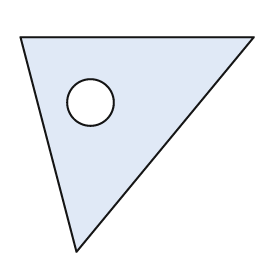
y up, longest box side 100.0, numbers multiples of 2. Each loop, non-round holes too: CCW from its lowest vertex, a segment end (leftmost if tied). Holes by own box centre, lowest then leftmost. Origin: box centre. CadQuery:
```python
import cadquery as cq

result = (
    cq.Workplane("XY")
    .moveTo(-26.0, -46.0)
    .lineTo(50.0, 46.0)
    .lineTo(-50.0, 46.0)
    .close()
    .moveTo(-20.0, 18.0)
    .circle(10.0)
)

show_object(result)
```